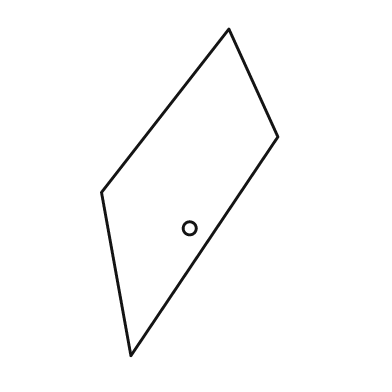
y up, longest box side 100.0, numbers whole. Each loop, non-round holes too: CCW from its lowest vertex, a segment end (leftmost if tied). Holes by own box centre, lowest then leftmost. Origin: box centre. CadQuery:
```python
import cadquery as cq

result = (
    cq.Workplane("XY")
    .moveTo(-18.0, -50.0)
    .lineTo(27.0, 17.0)
    .lineTo(12.0, 50.0)
    .lineTo(-27.0, 0.0)
    .close()
    .moveTo(0.0, -11.0)
    .circle(2.0)
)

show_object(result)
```